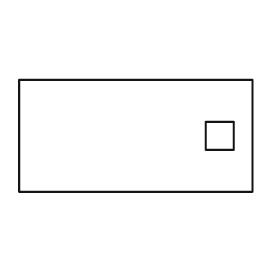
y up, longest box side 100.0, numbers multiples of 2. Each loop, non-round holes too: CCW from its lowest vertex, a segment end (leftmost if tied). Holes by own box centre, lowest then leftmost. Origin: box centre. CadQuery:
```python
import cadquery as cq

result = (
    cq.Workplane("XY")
    .moveTo(-50.0, -24.0)
    .lineTo(50.0, -24.0)
    .lineTo(50.0, 24.0)
    .lineTo(-50.0, 24.0)
    .close()
    .moveTo(30.0, -6.0)
    .lineTo(42.0, -6.0)
    .lineTo(42.0, 6.0)
    .lineTo(30.0, 6.0)
    .close()
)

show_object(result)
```